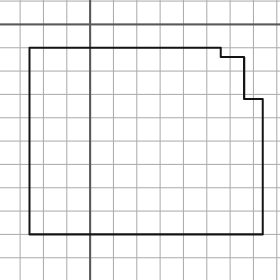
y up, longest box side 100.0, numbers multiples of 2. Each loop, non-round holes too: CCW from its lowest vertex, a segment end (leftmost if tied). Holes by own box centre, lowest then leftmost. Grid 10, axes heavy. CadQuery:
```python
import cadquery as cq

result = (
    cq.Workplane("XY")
    .moveTo(-26.0, -90.0)
    .lineTo(74.0, -90.0)
    .lineTo(74.0, -32.0)
    .lineTo(66.0, -32.0)
    .lineTo(66.0, -14.0)
    .lineTo(56.0, -14.0)
    .lineTo(56.0, -10.0)
    .lineTo(-26.0, -10.0)
    .close()
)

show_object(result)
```